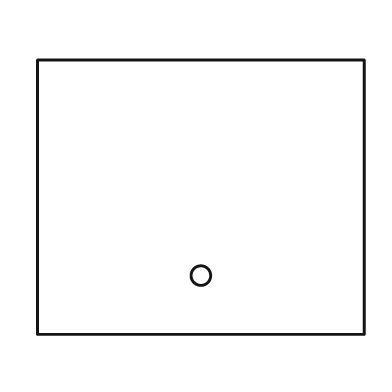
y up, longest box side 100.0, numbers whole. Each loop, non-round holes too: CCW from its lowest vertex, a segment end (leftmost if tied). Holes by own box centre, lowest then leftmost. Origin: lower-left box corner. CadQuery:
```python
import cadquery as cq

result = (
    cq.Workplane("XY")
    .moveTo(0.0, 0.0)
    .lineTo(100.0, 0.0)
    .lineTo(100.0, 84.0)
    .lineTo(0.0, 84.0)
    .close()
    .moveTo(50.0, 18.0)
    .circle(3.0)
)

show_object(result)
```